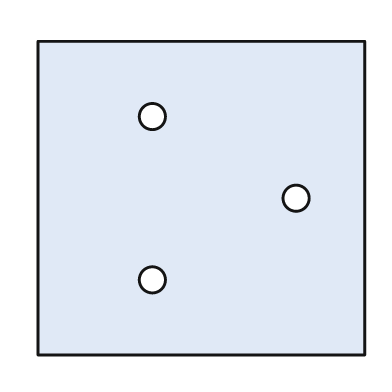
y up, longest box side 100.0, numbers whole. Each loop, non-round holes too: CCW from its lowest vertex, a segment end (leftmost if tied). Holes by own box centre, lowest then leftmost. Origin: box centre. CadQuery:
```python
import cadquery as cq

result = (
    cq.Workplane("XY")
    .moveTo(-50.0, -48.0)
    .lineTo(50.0, -48.0)
    .lineTo(50.0, 48.0)
    .lineTo(-50.0, 48.0)
    .close()
    .moveTo(-15.0, -25.0)
    .circle(4.0)
    .moveTo(29.0, 0.0)
    .circle(4.0)
    .moveTo(-15.0, 25.0)
    .circle(4.0)
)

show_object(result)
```